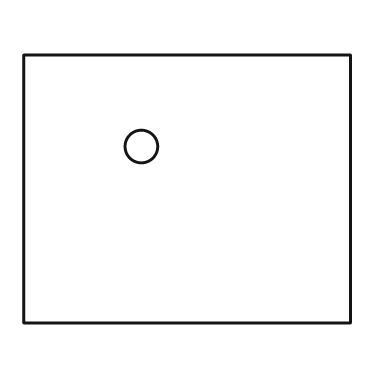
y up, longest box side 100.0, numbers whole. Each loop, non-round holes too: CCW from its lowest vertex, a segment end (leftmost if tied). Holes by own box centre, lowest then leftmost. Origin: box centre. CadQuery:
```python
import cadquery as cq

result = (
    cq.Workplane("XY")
    .moveTo(-50.0, -41.0)
    .lineTo(50.0, -41.0)
    .lineTo(50.0, 41.0)
    .lineTo(-50.0, 41.0)
    .close()
    .moveTo(-14.0, 13.0)
    .circle(5.0)
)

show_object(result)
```